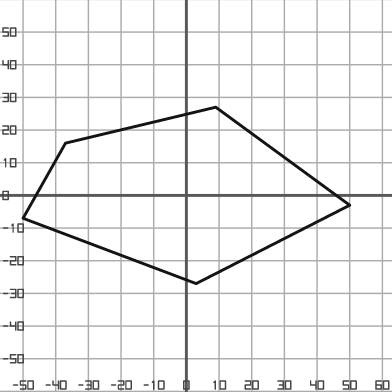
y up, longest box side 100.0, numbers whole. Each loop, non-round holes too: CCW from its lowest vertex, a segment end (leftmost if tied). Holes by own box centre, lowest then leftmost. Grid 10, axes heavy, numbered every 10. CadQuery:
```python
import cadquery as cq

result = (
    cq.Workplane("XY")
    .moveTo(3.0, -27.0)
    .lineTo(50.0, -3.0)
    .lineTo(9.0, 27.0)
    .lineTo(-37.0, 16.0)
    .lineTo(-50.0, -7.0)
    .close()
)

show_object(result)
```